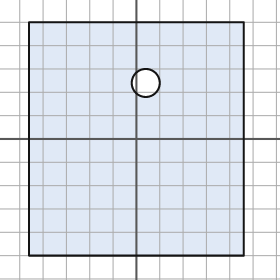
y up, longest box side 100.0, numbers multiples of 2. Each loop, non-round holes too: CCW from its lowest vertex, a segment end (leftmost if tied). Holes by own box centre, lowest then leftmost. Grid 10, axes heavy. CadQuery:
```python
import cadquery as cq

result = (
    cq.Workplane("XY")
    .moveTo(-46.0, -50.0)
    .lineTo(46.0, -50.0)
    .lineTo(46.0, 50.0)
    .lineTo(-46.0, 50.0)
    .close()
    .moveTo(4.0, 24.0)
    .circle(6.0)
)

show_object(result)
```